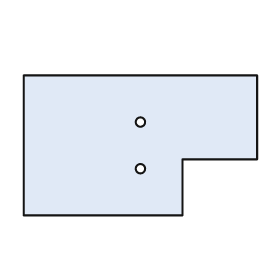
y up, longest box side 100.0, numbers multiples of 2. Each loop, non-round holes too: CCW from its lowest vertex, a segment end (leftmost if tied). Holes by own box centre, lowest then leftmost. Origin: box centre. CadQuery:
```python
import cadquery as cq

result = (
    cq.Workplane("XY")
    .moveTo(-50.0, -30.0)
    .lineTo(18.0, -30.0)
    .lineTo(18.0, -6.0)
    .lineTo(50.0, -6.0)
    .lineTo(50.0, 30.0)
    .lineTo(-50.0, 30.0)
    .close()
    .moveTo(0.0, -10.0)
    .circle(2.0)
    .moveTo(0.0, 10.0)
    .circle(2.0)
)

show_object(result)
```